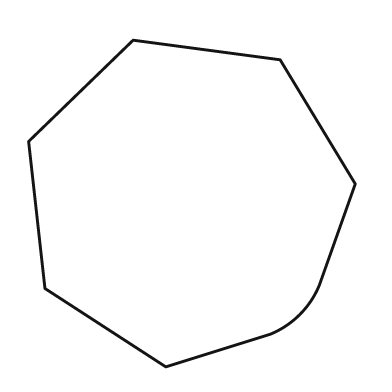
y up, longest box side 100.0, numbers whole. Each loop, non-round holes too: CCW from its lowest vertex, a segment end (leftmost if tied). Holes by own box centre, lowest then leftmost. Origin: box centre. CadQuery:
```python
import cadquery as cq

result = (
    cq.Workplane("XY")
    .moveTo(-8.0, -50.0)
    .lineTo(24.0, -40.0)
    .threePointArc((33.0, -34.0), (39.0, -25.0))
    .lineTo(50.0, 6.0)
    .lineTo(27.0, 44.0)
    .lineTo(-18.0, 50.0)
    .lineTo(-50.0, 19.0)
    .lineTo(-45.0, -26.0)
    .close()
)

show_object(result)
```